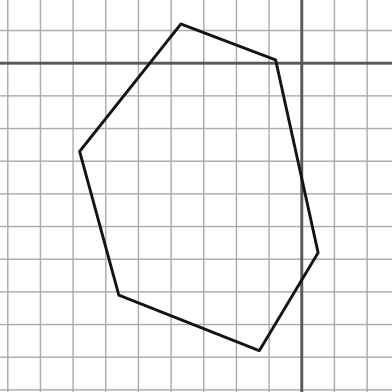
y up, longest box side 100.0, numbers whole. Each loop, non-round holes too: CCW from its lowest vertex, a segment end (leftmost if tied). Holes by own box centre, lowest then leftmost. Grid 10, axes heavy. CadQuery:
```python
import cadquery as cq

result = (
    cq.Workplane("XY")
    .moveTo(-13.0, -88.0)
    .lineTo(5.0, -58.0)
    .lineTo(-8.0, 1.0)
    .lineTo(-37.0, 12.0)
    .lineTo(-68.0, -27.0)
    .lineTo(-56.0, -71.0)
    .close()
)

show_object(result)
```